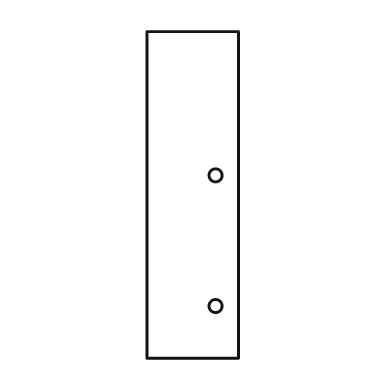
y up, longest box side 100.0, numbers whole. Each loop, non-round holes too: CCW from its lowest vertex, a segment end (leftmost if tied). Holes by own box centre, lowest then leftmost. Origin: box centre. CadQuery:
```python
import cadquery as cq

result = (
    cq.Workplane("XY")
    .moveTo(-14.0, -50.0)
    .lineTo(14.0, -50.0)
    .lineTo(14.0, 50.0)
    .lineTo(-14.0, 50.0)
    .close()
    .moveTo(7.0, -34.0)
    .circle(2.0)
    .moveTo(7.0, 6.0)
    .circle(2.0)
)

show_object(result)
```